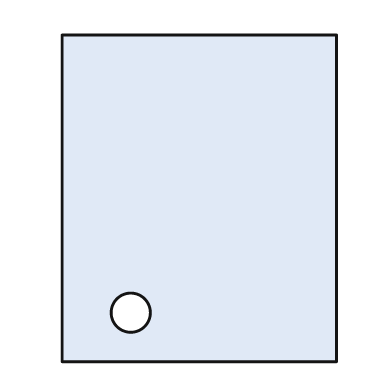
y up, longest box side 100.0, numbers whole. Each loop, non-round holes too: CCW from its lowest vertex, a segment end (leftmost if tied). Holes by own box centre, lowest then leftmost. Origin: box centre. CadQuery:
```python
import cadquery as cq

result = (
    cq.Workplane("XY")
    .moveTo(-42.0, -50.0)
    .lineTo(42.0, -50.0)
    .lineTo(42.0, 50.0)
    .lineTo(-42.0, 50.0)
    .close()
    .moveTo(-21.0, -35.0)
    .circle(6.0)
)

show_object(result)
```